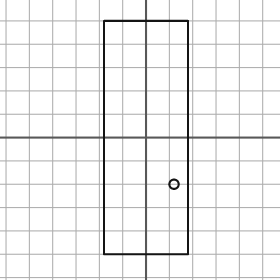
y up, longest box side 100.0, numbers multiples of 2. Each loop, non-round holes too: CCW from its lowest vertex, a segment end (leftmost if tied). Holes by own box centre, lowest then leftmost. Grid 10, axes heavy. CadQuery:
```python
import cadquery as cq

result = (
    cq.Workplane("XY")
    .moveTo(-18.0, -50.0)
    .lineTo(18.0, -50.0)
    .lineTo(18.0, 50.0)
    .lineTo(-18.0, 50.0)
    .close()
    .moveTo(12.0, -20.0)
    .circle(2.0)
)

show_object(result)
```